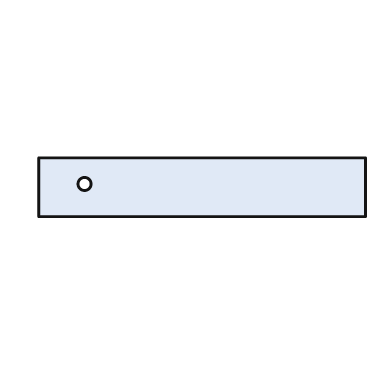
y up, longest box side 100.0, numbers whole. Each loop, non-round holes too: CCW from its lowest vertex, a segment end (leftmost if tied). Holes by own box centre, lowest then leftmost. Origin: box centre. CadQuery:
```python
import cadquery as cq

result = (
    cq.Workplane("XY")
    .moveTo(-50.0, -9.0)
    .lineTo(50.0, -9.0)
    .lineTo(50.0, 9.0)
    .lineTo(-50.0, 9.0)
    .close()
    .moveTo(-36.0, 1.0)
    .circle(2.0)
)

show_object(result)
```